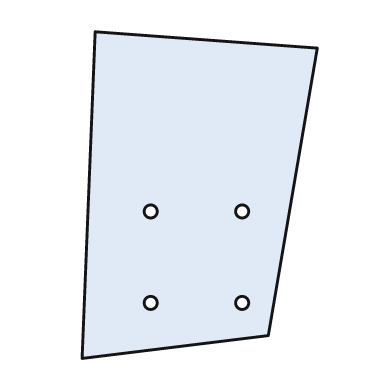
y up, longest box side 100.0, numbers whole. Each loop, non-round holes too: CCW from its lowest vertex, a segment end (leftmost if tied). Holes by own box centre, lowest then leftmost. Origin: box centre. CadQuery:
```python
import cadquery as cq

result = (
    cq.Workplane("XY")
    .moveTo(-36.0, -50.0)
    .lineTo(21.0, -43.0)
    .lineTo(36.0, 45.0)
    .lineTo(-32.0, 50.0)
    .close()
    .moveTo(-15.0, -33.0)
    .circle(2.0)
    .moveTo(13.0, -33.0)
    .circle(2.0)
    .moveTo(-15.0, -5.0)
    .circle(2.0)
    .moveTo(13.0, -5.0)
    .circle(2.0)
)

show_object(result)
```